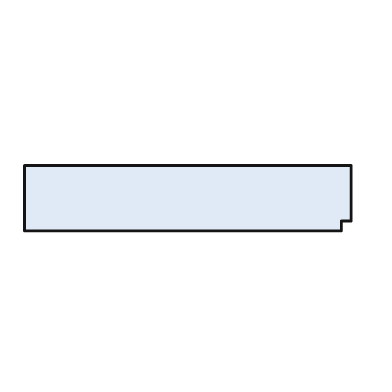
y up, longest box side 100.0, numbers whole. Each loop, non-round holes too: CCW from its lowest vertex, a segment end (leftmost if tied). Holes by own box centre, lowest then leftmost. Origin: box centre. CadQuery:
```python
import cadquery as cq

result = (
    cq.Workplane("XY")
    .moveTo(-50.0, -10.0)
    .lineTo(47.0, -10.0)
    .lineTo(47.0, -7.0)
    .lineTo(50.0, -7.0)
    .lineTo(50.0, 10.0)
    .lineTo(-50.0, 10.0)
    .close()
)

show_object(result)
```